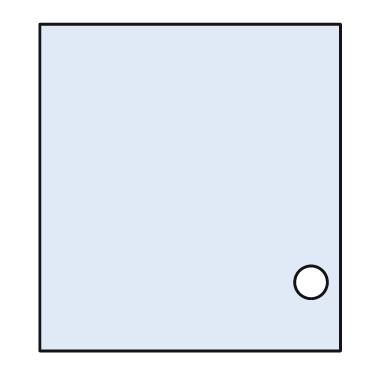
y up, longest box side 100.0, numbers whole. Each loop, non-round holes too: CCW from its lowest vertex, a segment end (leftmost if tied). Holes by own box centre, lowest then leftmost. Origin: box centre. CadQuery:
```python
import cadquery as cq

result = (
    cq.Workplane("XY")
    .moveTo(-46.0, -50.0)
    .lineTo(46.0, -50.0)
    .lineTo(46.0, 50.0)
    .lineTo(-46.0, 50.0)
    .close()
    .moveTo(37.0, -29.0)
    .circle(5.0)
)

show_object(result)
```